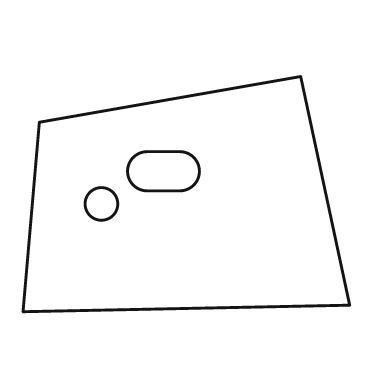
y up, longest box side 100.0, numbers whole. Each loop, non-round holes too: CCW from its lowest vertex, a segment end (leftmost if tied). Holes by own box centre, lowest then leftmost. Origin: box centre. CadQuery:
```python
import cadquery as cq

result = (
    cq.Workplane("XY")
    .moveTo(-50.0, -36.0)
    .lineTo(50.0, -34.0)
    .lineTo(35.0, 36.0)
    .lineTo(-45.0, 22.0)
    .close()
    .moveTo(-26.0, -3.0)
    .circle(5.0)
    .moveTo(-12.0, 1.0)
    .lineTo(-2.0, 1.0)
    .threePointArc((4.0, 7.0), (-2.0, 13.0))
    .lineTo(-12.0, 13.0)
    .threePointArc((-18.0, 7.0), (-12.0, 1.0))
    .close()
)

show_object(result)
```